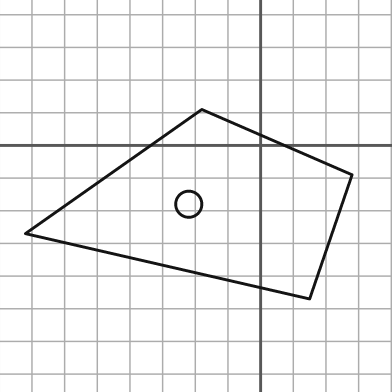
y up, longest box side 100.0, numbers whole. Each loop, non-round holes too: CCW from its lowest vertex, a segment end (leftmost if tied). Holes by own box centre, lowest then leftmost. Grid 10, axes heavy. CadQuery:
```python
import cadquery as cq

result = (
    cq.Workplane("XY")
    .moveTo(15.0, -47.0)
    .lineTo(28.0, -9.0)
    .lineTo(-18.0, 11.0)
    .lineTo(-72.0, -27.0)
    .close()
    .moveTo(-22.0, -18.0)
    .circle(4.0)
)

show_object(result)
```